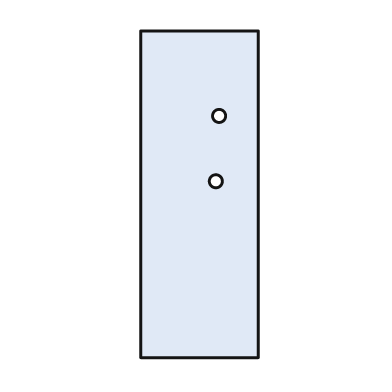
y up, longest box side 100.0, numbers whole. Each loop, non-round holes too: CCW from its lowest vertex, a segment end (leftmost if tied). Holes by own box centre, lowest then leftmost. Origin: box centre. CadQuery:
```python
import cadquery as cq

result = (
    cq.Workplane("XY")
    .moveTo(-18.0, -50.0)
    .lineTo(18.0, -50.0)
    .lineTo(18.0, 50.0)
    .lineTo(-18.0, 50.0)
    .close()
    .moveTo(5.0, 4.0)
    .circle(2.0)
    .moveTo(6.0, 24.0)
    .circle(2.0)
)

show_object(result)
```